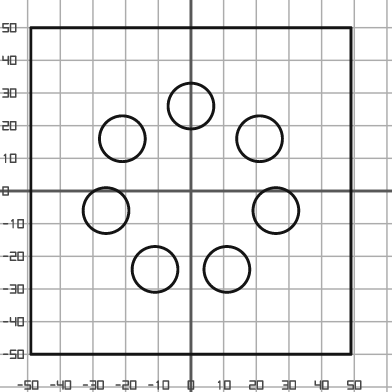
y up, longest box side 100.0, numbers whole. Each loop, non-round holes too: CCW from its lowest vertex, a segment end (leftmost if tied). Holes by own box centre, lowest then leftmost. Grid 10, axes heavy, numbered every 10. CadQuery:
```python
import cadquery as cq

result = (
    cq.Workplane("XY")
    .moveTo(-49.0, -50.0)
    .lineTo(49.0, -50.0)
    .lineTo(49.0, 50.0)
    .lineTo(-49.0, 50.0)
    .close()
    .moveTo(-11.0, -24.0)
    .circle(7.0)
    .moveTo(11.0, -24.0)
    .circle(7.0)
    .moveTo(-26.0, -6.0)
    .circle(7.0)
    .moveTo(26.0, -6.0)
    .circle(7.0)
    .moveTo(-21.0, 16.0)
    .circle(7.0)
    .moveTo(21.0, 16.0)
    .circle(7.0)
    .moveTo(0.0, 26.0)
    .circle(7.0)
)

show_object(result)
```